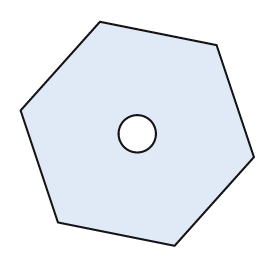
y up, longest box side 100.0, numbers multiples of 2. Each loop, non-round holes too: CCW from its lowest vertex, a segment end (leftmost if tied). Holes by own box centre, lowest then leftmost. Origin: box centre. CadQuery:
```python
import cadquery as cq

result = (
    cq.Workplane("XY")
    .moveTo(16.0, -48.0)
    .lineTo(50.0, -10.0)
    .lineTo(34.0, 38.0)
    .lineTo(-16.0, 48.0)
    .lineTo(-50.0, 10.0)
    .lineTo(-34.0, -38.0)
    .close()
    .moveTo(0.0, 0.0)
    .circle(8.0)
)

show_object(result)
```